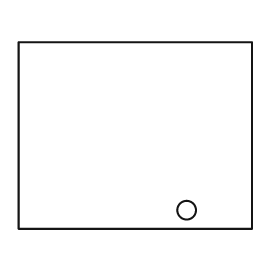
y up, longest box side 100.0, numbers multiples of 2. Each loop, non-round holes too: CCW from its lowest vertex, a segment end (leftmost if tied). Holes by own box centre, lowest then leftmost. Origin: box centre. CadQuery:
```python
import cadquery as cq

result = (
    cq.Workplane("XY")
    .moveTo(-50.0, -40.0)
    .lineTo(50.0, -40.0)
    .lineTo(50.0, 40.0)
    .lineTo(-50.0, 40.0)
    .close()
    .moveTo(22.0, -32.0)
    .circle(4.0)
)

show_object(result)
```